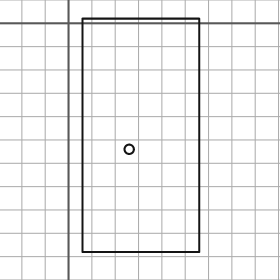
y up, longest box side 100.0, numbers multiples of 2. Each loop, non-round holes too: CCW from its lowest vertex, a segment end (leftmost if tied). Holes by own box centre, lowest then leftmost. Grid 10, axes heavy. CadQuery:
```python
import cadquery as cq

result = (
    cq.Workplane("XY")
    .moveTo(6.0, -98.0)
    .lineTo(56.0, -98.0)
    .lineTo(56.0, 2.0)
    .lineTo(6.0, 2.0)
    .close()
    .moveTo(26.0, -54.0)
    .circle(2.0)
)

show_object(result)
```